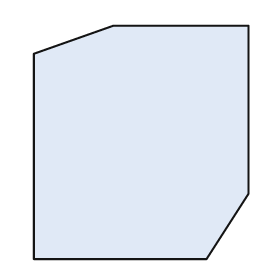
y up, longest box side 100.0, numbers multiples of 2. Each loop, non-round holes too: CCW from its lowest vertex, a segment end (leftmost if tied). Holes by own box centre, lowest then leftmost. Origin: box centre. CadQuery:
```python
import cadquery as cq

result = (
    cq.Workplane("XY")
    .moveTo(-46.0, -50.0)
    .lineTo(28.0, -50.0)
    .lineTo(46.0, -22.0)
    .lineTo(46.0, 50.0)
    .lineTo(-12.0, 50.0)
    .lineTo(-46.0, 38.0)
    .close()
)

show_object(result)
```